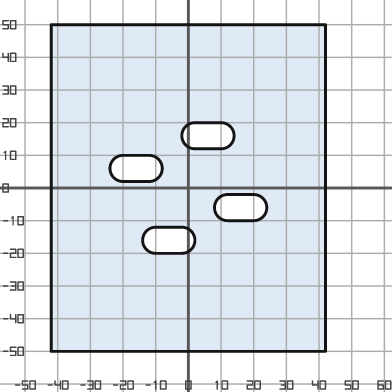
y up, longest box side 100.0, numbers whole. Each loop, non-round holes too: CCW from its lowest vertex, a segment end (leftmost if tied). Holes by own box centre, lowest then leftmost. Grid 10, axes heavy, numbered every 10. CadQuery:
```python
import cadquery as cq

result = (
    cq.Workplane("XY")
    .moveTo(-42.0, -50.0)
    .lineTo(42.0, -50.0)
    .lineTo(42.0, 50.0)
    .lineTo(-42.0, 50.0)
    .close()
    .moveTo(-10.0, -20.0)
    .lineTo(-2.0, -20.0)
    .threePointArc((2.0, -16.0), (-2.0, -12.0))
    .lineTo(-10.0, -12.0)
    .threePointArc((-14.0, -16.0), (-10.0, -20.0))
    .close()
    .moveTo(12.0, -10.0)
    .lineTo(20.0, -10.0)
    .threePointArc((24.0, -6.0), (20.0, -2.0))
    .lineTo(12.0, -2.0)
    .threePointArc((8.0, -6.0), (12.0, -10.0))
    .close()
    .moveTo(-20.0, 2.0)
    .lineTo(-12.0, 2.0)
    .threePointArc((-8.0, 6.0), (-12.0, 10.0))
    .lineTo(-20.0, 10.0)
    .threePointArc((-24.0, 6.0), (-20.0, 2.0))
    .close()
    .moveTo(2.0, 12.0)
    .lineTo(10.0, 12.0)
    .threePointArc((14.0, 16.0), (10.0, 20.0))
    .lineTo(2.0, 20.0)
    .threePointArc((-2.0, 16.0), (2.0, 12.0))
    .close()
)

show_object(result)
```